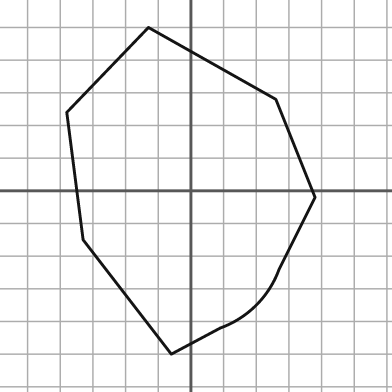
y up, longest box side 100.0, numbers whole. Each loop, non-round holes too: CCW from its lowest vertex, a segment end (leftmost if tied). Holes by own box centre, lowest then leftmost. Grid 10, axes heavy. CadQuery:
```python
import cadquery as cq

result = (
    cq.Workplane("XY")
    .moveTo(-6.0, -50.0)
    .lineTo(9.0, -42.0)
    .threePointArc((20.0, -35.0), (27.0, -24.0))
    .lineTo(38.0, -2.0)
    .lineTo(26.0, 28.0)
    .lineTo(-13.0, 50.0)
    .lineTo(-38.0, 24.0)
    .lineTo(-33.0, -15.0)
    .close()
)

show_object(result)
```